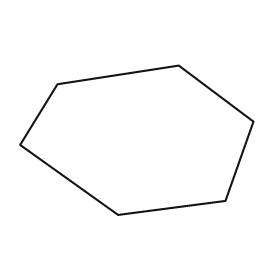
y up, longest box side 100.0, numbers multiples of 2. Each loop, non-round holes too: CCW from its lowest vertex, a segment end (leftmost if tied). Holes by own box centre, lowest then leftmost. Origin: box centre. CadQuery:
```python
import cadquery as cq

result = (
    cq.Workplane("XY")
    .moveTo(-8.0, -32.0)
    .lineTo(38.0, -26.0)
    .lineTo(50.0, 8.0)
    .lineTo(18.0, 32.0)
    .lineTo(-34.0, 24.0)
    .lineTo(-50.0, -2.0)
    .close()
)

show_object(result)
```